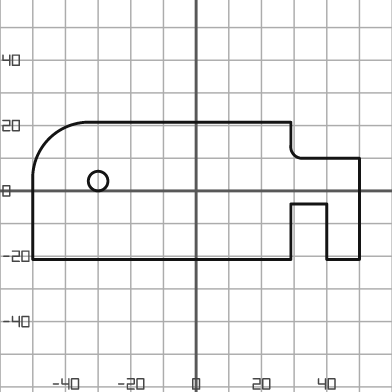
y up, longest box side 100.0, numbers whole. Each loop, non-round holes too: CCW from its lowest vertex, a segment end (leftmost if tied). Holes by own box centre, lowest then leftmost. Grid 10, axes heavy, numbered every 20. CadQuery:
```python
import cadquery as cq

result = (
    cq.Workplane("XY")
    .moveTo(-50.0, -21.0)
    .lineTo(29.0, -21.0)
    .lineTo(29.0, -4.0)
    .lineTo(40.0, -4.0)
    .lineTo(40.0, -21.0)
    .lineTo(50.0, -21.0)
    .lineTo(50.0, 10.0)
    .lineTo(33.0, 10.0)
    .threePointArc((30.0, 11.0), (29.0, 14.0))
    .lineTo(29.0, 21.0)
    .lineTo(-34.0, 21.0)
    .threePointArc((-45.0, 16.0), (-50.0, 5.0))
    .close()
    .moveTo(-30.0, 3.0)
    .circle(3.0)
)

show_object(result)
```